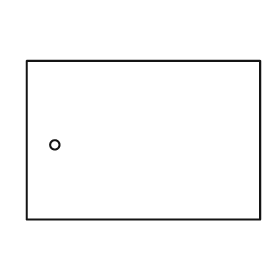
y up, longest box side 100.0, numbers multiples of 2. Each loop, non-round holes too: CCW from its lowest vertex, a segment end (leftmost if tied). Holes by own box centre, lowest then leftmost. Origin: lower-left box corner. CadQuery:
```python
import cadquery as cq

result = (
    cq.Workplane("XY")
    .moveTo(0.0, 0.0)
    .lineTo(100.0, 0.0)
    .lineTo(100.0, 68.0)
    .lineTo(0.0, 68.0)
    .close()
    .moveTo(12.0, 32.0)
    .circle(2.0)
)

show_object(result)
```